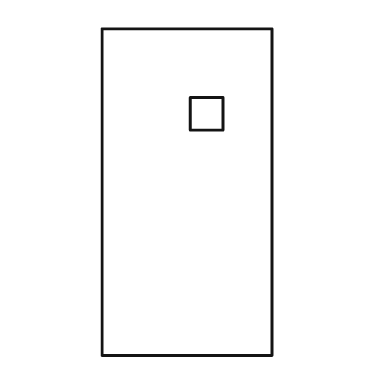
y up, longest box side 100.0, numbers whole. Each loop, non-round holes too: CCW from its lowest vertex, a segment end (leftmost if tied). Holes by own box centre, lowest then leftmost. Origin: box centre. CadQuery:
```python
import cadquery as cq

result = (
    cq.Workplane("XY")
    .moveTo(-26.0, -50.0)
    .lineTo(26.0, -50.0)
    .lineTo(26.0, 50.0)
    .lineTo(-26.0, 50.0)
    .close()
    .moveTo(1.0, 19.0)
    .lineTo(11.0, 19.0)
    .lineTo(11.0, 29.0)
    .lineTo(1.0, 29.0)
    .close()
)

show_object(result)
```